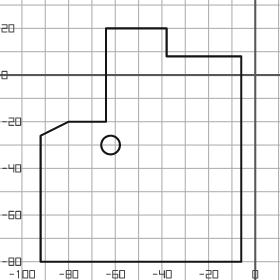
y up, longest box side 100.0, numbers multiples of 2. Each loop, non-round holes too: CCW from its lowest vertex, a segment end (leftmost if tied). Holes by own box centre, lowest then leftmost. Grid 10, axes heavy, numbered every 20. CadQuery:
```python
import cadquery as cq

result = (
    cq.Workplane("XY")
    .moveTo(-92.0, -80.0)
    .lineTo(-6.0, -80.0)
    .lineTo(-6.0, 8.0)
    .lineTo(-38.0, 8.0)
    .lineTo(-38.0, 20.0)
    .lineTo(-64.0, 20.0)
    .lineTo(-64.0, -20.0)
    .lineTo(-80.0, -20.0)
    .lineTo(-92.0, -26.0)
    .close()
    .moveTo(-62.0, -30.0)
    .circle(4.0)
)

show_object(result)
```